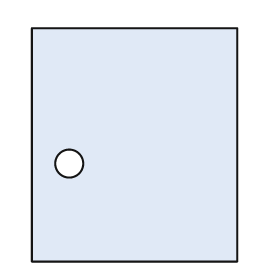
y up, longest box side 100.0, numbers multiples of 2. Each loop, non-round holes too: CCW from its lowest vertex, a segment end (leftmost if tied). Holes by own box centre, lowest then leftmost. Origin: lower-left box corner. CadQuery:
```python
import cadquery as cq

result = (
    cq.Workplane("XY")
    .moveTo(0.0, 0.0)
    .lineTo(88.0, 0.0)
    .lineTo(88.0, 100.0)
    .lineTo(0.0, 100.0)
    .close()
    .moveTo(16.0, 42.0)
    .circle(6.0)
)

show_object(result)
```